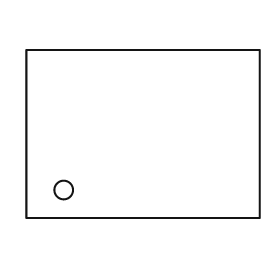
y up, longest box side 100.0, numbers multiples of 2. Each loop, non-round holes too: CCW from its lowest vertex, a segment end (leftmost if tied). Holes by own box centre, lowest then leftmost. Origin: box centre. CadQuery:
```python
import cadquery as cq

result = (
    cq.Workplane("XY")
    .moveTo(-50.0, -36.0)
    .lineTo(50.0, -36.0)
    .lineTo(50.0, 36.0)
    .lineTo(-50.0, 36.0)
    .close()
    .moveTo(-34.0, -24.0)
    .circle(4.0)
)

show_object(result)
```